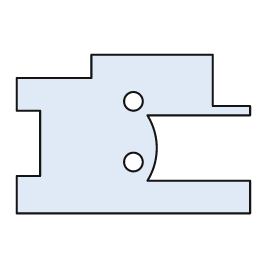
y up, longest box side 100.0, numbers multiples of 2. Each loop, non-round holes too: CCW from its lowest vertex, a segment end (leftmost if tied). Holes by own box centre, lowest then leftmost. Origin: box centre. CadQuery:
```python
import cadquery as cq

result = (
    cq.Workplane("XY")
    .moveTo(-50.0, -34.0)
    .lineTo(50.0, -34.0)
    .lineTo(50.0, -20.0)
    .lineTo(6.0, -20.0)
    .threePointArc((10.0, -6.0), (6.0, 8.0))
    .lineTo(50.0, 8.0)
    .lineTo(50.0, 12.0)
    .lineTo(34.0, 12.0)
    .lineTo(34.0, 34.0)
    .lineTo(-18.0, 34.0)
    .lineTo(-18.0, 24.0)
    .lineTo(-50.0, 24.0)
    .lineTo(-50.0, 10.0)
    .lineTo(-40.0, 10.0)
    .lineTo(-40.0, -18.0)
    .lineTo(-50.0, -18.0)
    .close()
    .moveTo(0.0, -12.0)
    .circle(4.0)
    .moveTo(0.0, 14.0)
    .circle(4.0)
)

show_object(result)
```